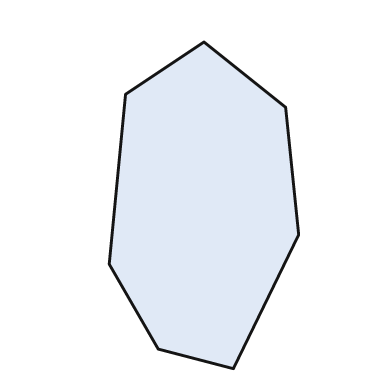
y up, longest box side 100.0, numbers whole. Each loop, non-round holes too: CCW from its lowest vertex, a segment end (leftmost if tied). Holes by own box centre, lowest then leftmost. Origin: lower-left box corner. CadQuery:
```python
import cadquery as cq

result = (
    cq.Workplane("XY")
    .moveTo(38.0, 0.0)
    .lineTo(58.0, 41.0)
    .lineTo(54.0, 80.0)
    .lineTo(29.0, 100.0)
    .lineTo(5.0, 84.0)
    .lineTo(0.0, 32.0)
    .lineTo(15.0, 6.0)
    .close()
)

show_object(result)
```